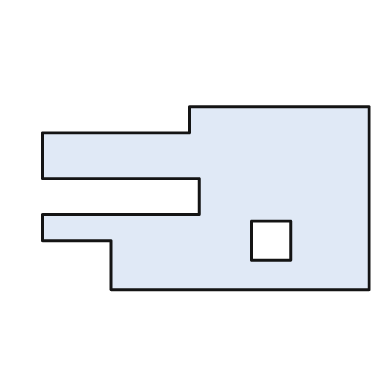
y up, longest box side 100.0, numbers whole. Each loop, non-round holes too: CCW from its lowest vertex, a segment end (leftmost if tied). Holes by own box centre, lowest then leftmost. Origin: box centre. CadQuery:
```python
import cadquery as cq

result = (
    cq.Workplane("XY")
    .moveTo(-29.0, -28.0)
    .lineTo(50.0, -28.0)
    .lineTo(50.0, 28.0)
    .lineTo(-5.0, 28.0)
    .lineTo(-5.0, 20.0)
    .lineTo(-50.0, 20.0)
    .lineTo(-50.0, 6.0)
    .lineTo(-2.0, 6.0)
    .lineTo(-2.0, -5.0)
    .lineTo(-50.0, -5.0)
    .lineTo(-50.0, -13.0)
    .lineTo(-29.0, -13.0)
    .close()
    .moveTo(14.0, -19.0)
    .lineTo(26.0, -19.0)
    .lineTo(26.0, -7.0)
    .lineTo(14.0, -7.0)
    .close()
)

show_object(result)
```